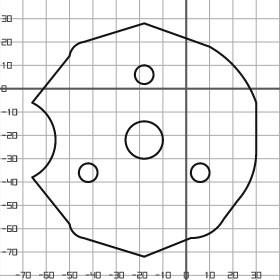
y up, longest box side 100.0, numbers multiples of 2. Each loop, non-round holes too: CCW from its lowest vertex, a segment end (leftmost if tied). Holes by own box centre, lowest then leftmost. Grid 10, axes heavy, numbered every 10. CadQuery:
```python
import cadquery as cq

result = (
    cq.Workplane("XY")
    .moveTo(-18.0, -72.0)
    .lineTo(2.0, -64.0)
    .threePointArc((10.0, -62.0), (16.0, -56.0))
    .lineTo(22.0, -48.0)
    .threePointArc((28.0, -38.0), (30.0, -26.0))
    .lineTo(30.0, -6.0)
    .threePointArc((22.0, 8.0), (10.0, 18.0))
    .lineTo(-18.0, 28.0)
    .lineTo(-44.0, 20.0)
    .threePointArc((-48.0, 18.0), (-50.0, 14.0))
    .lineTo(-66.0, -6.0)
    .threePointArc((-56.0, -22.0), (-66.0, -38.0))
    .lineTo(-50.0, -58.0)
    .threePointArc((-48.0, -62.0), (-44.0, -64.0))
    .close()
    .moveTo(-42.0, -36.0)
    .circle(4.0)
    .moveTo(6.0, -36.0)
    .circle(4.0)
    .moveTo(-18.0, -22.0)
    .circle(8.0)
    .moveTo(-18.0, 6.0)
    .circle(4.0)
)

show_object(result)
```